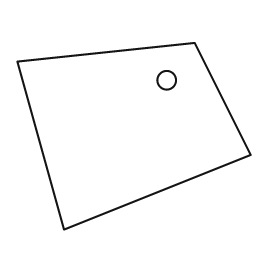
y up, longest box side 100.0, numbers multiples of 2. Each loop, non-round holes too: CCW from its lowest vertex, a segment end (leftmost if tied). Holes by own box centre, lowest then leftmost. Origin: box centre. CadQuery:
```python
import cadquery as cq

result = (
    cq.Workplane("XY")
    .moveTo(-30.0, -40.0)
    .lineTo(50.0, -8.0)
    .lineTo(26.0, 40.0)
    .lineTo(-50.0, 32.0)
    .close()
    .moveTo(14.0, 24.0)
    .circle(4.0)
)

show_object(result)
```